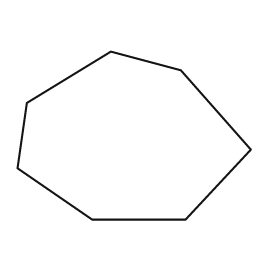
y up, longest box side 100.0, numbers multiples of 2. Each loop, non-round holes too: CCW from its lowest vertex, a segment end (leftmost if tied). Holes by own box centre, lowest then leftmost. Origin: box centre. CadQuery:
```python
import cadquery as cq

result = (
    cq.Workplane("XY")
    .moveTo(-18.0, -36.0)
    .lineTo(22.0, -36.0)
    .lineTo(50.0, -6.0)
    .lineTo(20.0, 28.0)
    .lineTo(-10.0, 36.0)
    .lineTo(-46.0, 14.0)
    .lineTo(-50.0, -14.0)
    .close()
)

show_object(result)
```